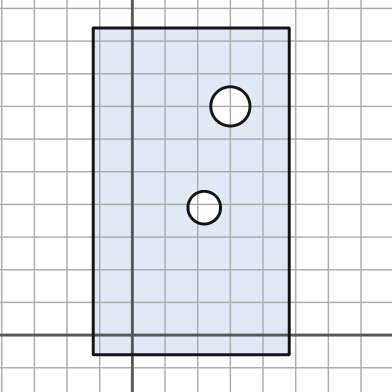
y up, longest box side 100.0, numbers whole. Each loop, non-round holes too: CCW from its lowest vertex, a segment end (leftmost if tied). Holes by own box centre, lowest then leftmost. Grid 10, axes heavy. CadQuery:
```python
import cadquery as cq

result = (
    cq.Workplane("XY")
    .moveTo(-12.0, -6.0)
    .lineTo(48.0, -6.0)
    .lineTo(48.0, 94.0)
    .lineTo(-12.0, 94.0)
    .close()
    .moveTo(22.0, 39.0)
    .circle(5.0)
    .moveTo(30.0, 70.0)
    .circle(6.0)
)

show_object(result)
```